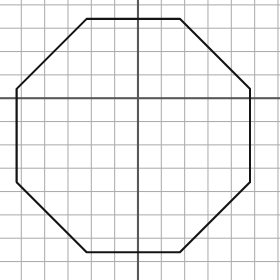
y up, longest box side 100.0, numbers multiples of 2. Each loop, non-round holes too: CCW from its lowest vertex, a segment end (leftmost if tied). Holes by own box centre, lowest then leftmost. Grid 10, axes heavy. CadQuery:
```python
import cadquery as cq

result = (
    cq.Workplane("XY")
    .moveTo(-22.0, -66.0)
    .lineTo(18.0, -66.0)
    .lineTo(48.0, -36.0)
    .lineTo(48.0, 4.0)
    .lineTo(18.0, 34.0)
    .lineTo(-22.0, 34.0)
    .lineTo(-52.0, 4.0)
    .lineTo(-52.0, -36.0)
    .close()
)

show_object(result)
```